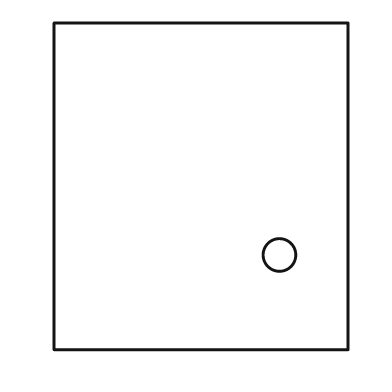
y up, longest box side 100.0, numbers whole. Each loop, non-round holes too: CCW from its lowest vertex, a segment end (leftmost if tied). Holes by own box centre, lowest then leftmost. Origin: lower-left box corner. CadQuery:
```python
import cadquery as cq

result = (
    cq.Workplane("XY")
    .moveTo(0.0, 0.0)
    .lineTo(90.0, 0.0)
    .lineTo(90.0, 100.0)
    .lineTo(0.0, 100.0)
    .close()
    .moveTo(69.0, 29.0)
    .circle(5.0)
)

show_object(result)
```